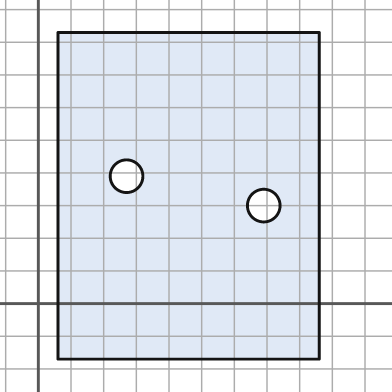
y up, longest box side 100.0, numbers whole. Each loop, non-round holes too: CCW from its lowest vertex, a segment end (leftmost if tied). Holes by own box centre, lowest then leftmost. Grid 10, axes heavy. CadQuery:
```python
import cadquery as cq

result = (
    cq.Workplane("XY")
    .moveTo(6.0, -17.0)
    .lineTo(86.0, -17.0)
    .lineTo(86.0, 83.0)
    .lineTo(6.0, 83.0)
    .close()
    .moveTo(69.0, 30.0)
    .circle(5.0)
    .moveTo(27.0, 39.0)
    .circle(5.0)
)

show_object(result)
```